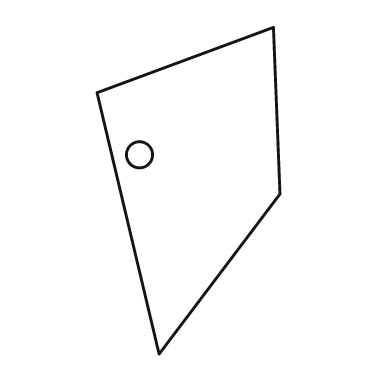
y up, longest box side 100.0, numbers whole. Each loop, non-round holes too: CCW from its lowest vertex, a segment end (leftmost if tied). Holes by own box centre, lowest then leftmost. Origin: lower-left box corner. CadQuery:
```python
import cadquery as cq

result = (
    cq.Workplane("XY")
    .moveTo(19.0, 0.0)
    .lineTo(56.0, 49.0)
    .lineTo(54.0, 100.0)
    .lineTo(0.0, 80.0)
    .close()
    .moveTo(13.0, 61.0)
    .circle(4.0)
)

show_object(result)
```